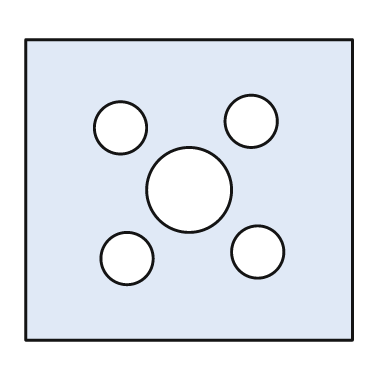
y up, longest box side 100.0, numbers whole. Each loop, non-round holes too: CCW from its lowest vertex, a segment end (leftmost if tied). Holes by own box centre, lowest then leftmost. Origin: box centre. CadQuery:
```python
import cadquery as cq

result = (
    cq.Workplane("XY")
    .moveTo(-50.0, -46.0)
    .lineTo(50.0, -46.0)
    .lineTo(50.0, 46.0)
    .lineTo(-50.0, 46.0)
    .close()
    .moveTo(-19.0, -21.0)
    .circle(8.0)
    .moveTo(21.0, -19.0)
    .circle(8.0)
    .moveTo(0.0, 0.0)
    .circle(13.0)
    .moveTo(-21.0, 19.0)
    .circle(8.0)
    .moveTo(19.0, 21.0)
    .circle(8.0)
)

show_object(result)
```